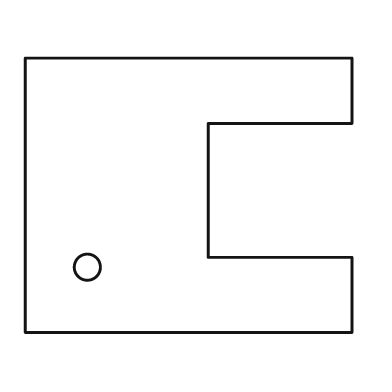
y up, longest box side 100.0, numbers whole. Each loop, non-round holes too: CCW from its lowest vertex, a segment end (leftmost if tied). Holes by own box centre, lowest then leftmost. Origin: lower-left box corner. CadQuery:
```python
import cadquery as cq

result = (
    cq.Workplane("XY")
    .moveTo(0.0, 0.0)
    .lineTo(100.0, 0.0)
    .lineTo(100.0, 23.0)
    .lineTo(56.0, 23.0)
    .lineTo(56.0, 64.0)
    .lineTo(100.0, 64.0)
    .lineTo(100.0, 84.0)
    .lineTo(0.0, 84.0)
    .close()
    .moveTo(19.0, 20.0)
    .circle(4.0)
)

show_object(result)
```